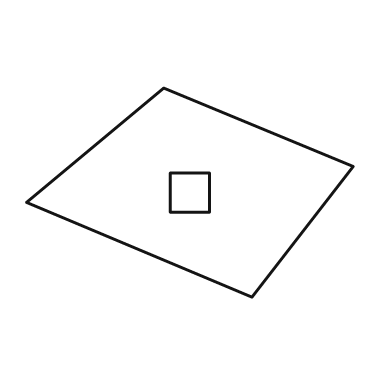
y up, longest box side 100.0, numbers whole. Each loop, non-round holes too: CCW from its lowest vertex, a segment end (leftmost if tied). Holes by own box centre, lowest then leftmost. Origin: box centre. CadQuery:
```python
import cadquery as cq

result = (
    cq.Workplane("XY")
    .moveTo(19.0, -32.0)
    .lineTo(50.0, 8.0)
    .lineTo(-8.0, 32.0)
    .lineTo(-50.0, -3.0)
    .close()
    .moveTo(-6.0, -6.0)
    .lineTo(6.0, -6.0)
    .lineTo(6.0, 6.0)
    .lineTo(-6.0, 6.0)
    .close()
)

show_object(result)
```